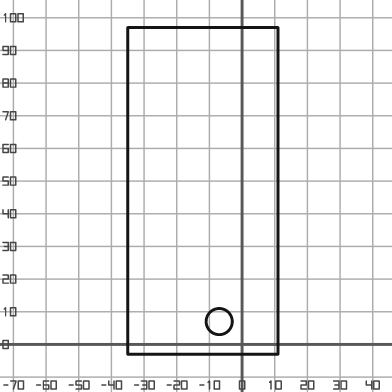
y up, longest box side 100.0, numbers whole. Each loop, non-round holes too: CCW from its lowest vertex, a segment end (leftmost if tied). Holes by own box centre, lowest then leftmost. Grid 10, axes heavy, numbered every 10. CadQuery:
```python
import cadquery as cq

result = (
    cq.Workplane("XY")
    .moveTo(-35.0, -3.0)
    .lineTo(11.0, -3.0)
    .lineTo(11.0, 97.0)
    .lineTo(-35.0, 97.0)
    .close()
    .moveTo(-7.0, 7.0)
    .circle(4.0)
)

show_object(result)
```